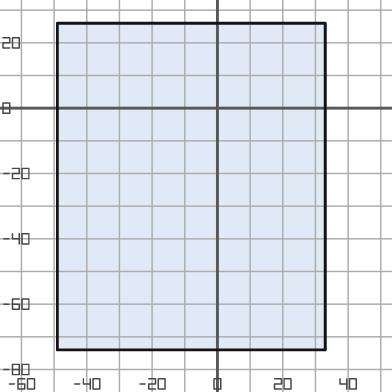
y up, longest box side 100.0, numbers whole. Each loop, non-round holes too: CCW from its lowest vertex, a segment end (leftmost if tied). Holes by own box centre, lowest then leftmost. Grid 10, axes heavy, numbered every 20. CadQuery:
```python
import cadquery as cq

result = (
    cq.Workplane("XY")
    .moveTo(-49.0, -74.0)
    .lineTo(33.0, -74.0)
    .lineTo(33.0, 26.0)
    .lineTo(-49.0, 26.0)
    .close()
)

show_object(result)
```